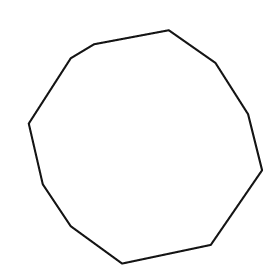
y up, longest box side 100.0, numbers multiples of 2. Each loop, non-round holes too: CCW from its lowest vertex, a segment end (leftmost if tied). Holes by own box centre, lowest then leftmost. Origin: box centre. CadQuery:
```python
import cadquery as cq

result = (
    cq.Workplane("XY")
    .moveTo(-10.0, -50.0)
    .lineTo(28.0, -42.0)
    .lineTo(50.0, -10.0)
    .lineTo(44.0, 14.0)
    .lineTo(30.0, 36.0)
    .lineTo(10.0, 50.0)
    .lineTo(-22.0, 44.0)
    .lineTo(-32.0, 38.0)
    .lineTo(-50.0, 10.0)
    .lineTo(-44.0, -16.0)
    .lineTo(-32.0, -34.0)
    .close()
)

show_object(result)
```